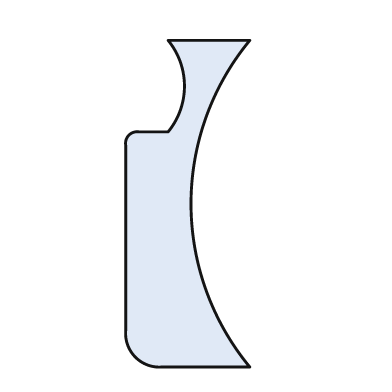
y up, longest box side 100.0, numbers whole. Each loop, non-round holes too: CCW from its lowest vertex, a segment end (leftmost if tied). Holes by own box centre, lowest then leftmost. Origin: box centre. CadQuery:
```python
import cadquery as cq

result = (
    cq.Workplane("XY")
    .moveTo(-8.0, -50.0)
    .lineTo(19.0, -50.0)
    .threePointArc((1.0, 0.0), (19.0, 50.0))
    .lineTo(-6.0, 50.0)
    .threePointArc((-1.0, 36.0), (-6.0, 22.0))
    .lineTo(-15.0, 22.0)
    .threePointArc((-18.0, 21.0), (-19.0, 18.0))
    .lineTo(-19.0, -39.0)
    .threePointArc((-16.0, -47.0), (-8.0, -50.0))
    .close()
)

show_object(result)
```